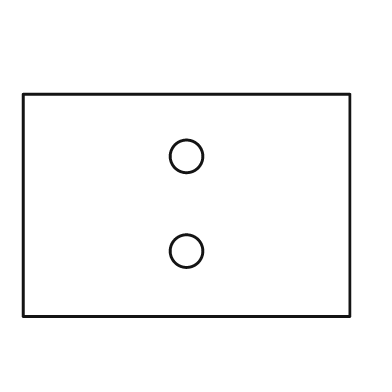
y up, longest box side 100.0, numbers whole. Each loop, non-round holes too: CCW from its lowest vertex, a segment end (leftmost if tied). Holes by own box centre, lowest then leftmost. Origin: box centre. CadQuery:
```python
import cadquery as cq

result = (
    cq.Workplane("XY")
    .moveTo(-50.0, -34.0)
    .lineTo(50.0, -34.0)
    .lineTo(50.0, 34.0)
    .lineTo(-50.0, 34.0)
    .close()
    .moveTo(0.0, -14.0)
    .circle(5.0)
    .moveTo(0.0, 15.0)
    .circle(5.0)
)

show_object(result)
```